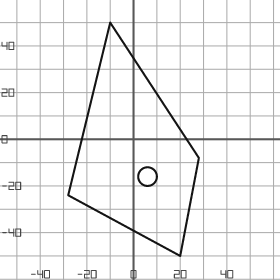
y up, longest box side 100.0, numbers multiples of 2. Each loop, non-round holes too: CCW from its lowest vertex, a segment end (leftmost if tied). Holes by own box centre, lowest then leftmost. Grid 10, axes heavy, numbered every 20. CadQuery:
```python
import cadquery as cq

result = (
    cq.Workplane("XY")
    .moveTo(20.0, -50.0)
    .lineTo(28.0, -8.0)
    .lineTo(-10.0, 50.0)
    .lineTo(-28.0, -24.0)
    .close()
    .moveTo(6.0, -16.0)
    .circle(4.0)
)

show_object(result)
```